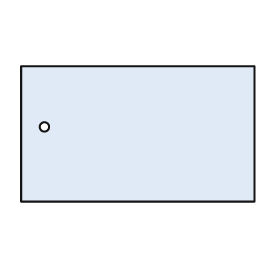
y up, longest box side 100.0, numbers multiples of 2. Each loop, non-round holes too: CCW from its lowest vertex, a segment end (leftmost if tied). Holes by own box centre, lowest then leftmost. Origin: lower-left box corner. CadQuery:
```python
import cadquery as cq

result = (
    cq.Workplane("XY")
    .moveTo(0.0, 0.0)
    .lineTo(100.0, 0.0)
    .lineTo(100.0, 58.0)
    .lineTo(0.0, 58.0)
    .close()
    .moveTo(10.0, 32.0)
    .circle(2.0)
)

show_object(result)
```